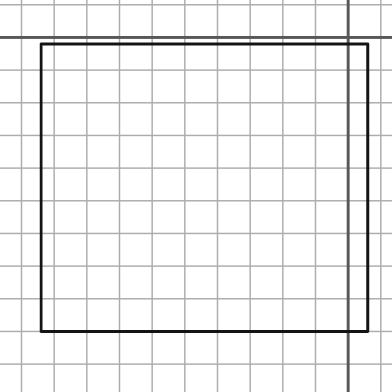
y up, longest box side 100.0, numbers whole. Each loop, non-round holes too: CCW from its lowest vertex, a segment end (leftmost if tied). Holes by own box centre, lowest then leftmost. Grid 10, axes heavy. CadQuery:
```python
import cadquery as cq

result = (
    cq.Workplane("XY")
    .moveTo(-94.0, -90.0)
    .lineTo(6.0, -90.0)
    .lineTo(6.0, -2.0)
    .lineTo(-94.0, -2.0)
    .close()
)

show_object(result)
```